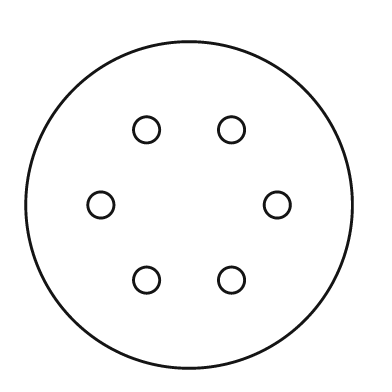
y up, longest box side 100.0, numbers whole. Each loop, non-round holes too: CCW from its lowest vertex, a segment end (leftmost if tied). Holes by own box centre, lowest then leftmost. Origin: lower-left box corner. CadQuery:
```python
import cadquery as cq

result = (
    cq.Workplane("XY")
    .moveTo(50.0, 50.0)
    .circle(50.0)
    .moveTo(37.0, 27.0)
    .circle(4.0)
    .moveTo(63.0, 27.0)
    .circle(4.0)
    .moveTo(23.0, 50.0)
    .circle(4.0)
    .moveTo(77.0, 50.0)
    .circle(4.0)
    .moveTo(37.0, 73.0)
    .circle(4.0)
    .moveTo(63.0, 73.0)
    .circle(4.0)
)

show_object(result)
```